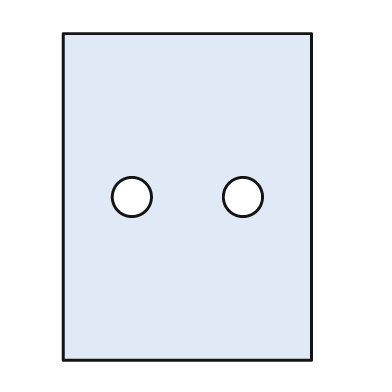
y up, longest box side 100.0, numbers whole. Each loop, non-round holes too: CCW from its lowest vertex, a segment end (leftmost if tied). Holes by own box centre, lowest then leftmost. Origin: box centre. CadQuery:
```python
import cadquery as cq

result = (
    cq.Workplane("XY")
    .moveTo(-38.0, -50.0)
    .lineTo(38.0, -50.0)
    .lineTo(38.0, 50.0)
    .lineTo(-38.0, 50.0)
    .close()
    .moveTo(-17.0, 0.0)
    .circle(6.0)
    .moveTo(17.0, 0.0)
    .circle(6.0)
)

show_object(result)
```